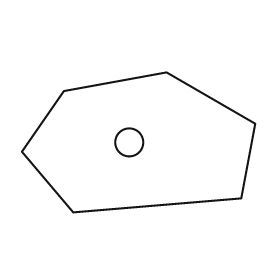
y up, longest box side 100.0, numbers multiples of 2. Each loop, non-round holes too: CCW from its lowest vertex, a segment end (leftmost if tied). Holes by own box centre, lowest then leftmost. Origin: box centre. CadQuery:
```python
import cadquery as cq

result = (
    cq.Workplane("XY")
    .moveTo(-28.0, -30.0)
    .lineTo(44.0, -24.0)
    .lineTo(50.0, 8.0)
    .lineTo(12.0, 30.0)
    .lineTo(-32.0, 22.0)
    .lineTo(-50.0, -4.0)
    .close()
    .moveTo(-4.0, 0.0)
    .circle(6.0)
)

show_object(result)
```